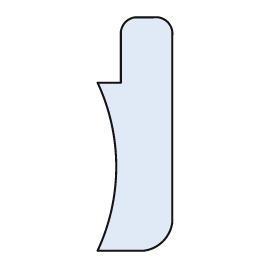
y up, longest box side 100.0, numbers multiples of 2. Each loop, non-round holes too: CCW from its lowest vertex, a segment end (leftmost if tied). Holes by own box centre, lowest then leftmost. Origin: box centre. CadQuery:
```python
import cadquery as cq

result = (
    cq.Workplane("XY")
    .moveTo(-16.0, -50.0)
    .lineTo(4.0, -50.0)
    .threePointArc((12.0, -46.0), (16.0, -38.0))
    .lineTo(16.0, 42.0)
    .threePointArc((14.0, 48.0), (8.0, 50.0))
    .lineTo(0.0, 50.0)
    .threePointArc((-4.0, 48.0), (-6.0, 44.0))
    .lineTo(-6.0, 22.0)
    .lineTo(-16.0, 22.0)
    .threePointArc((-8.0, -14.0), (-16.0, -50.0))
    .close()
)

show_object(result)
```